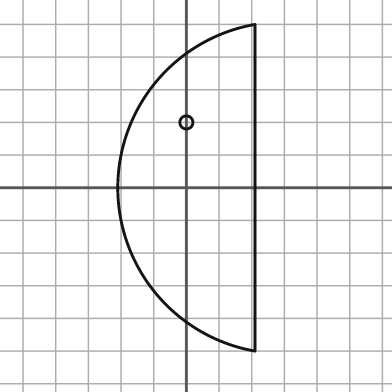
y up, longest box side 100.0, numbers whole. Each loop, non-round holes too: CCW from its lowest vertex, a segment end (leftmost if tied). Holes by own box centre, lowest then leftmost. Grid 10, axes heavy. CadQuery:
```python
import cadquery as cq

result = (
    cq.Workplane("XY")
    .moveTo(21.0, -50.0)
    .lineTo(21.0, 50.0)
    .threePointArc((-21.0, 0.0), (21.0, -50.0))
    .close()
    .moveTo(0.0, 20.0)
    .circle(2.0)
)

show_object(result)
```